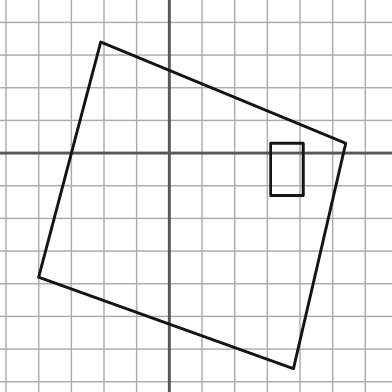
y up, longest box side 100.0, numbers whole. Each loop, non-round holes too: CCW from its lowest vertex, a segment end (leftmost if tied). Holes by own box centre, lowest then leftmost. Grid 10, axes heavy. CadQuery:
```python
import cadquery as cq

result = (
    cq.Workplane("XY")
    .moveTo(38.0, -66.0)
    .lineTo(54.0, 3.0)
    .lineTo(-21.0, 34.0)
    .lineTo(-40.0, -38.0)
    .close()
    .moveTo(31.0, -13.0)
    .lineTo(41.0, -13.0)
    .lineTo(41.0, 3.0)
    .lineTo(31.0, 3.0)
    .close()
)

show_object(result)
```